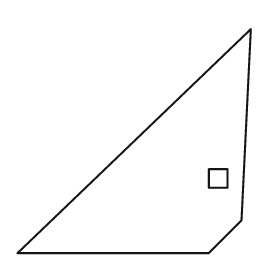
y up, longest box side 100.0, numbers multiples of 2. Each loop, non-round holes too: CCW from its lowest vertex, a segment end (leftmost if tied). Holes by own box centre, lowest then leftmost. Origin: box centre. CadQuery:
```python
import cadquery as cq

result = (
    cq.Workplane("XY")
    .moveTo(-50.0, -48.0)
    .lineTo(32.0, -48.0)
    .lineTo(46.0, -34.0)
    .lineTo(50.0, 48.0)
    .close()
    .moveTo(32.0, -20.0)
    .lineTo(40.0, -20.0)
    .lineTo(40.0, -12.0)
    .lineTo(32.0, -12.0)
    .close()
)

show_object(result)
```